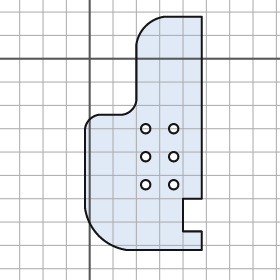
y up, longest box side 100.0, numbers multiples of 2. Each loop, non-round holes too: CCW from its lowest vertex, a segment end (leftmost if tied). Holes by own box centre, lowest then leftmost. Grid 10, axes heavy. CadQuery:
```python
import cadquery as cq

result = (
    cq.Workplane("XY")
    .moveTo(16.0, -82.0)
    .lineTo(48.0, -82.0)
    .lineTo(48.0, -74.0)
    .lineTo(40.0, -74.0)
    .lineTo(40.0, -60.0)
    .lineTo(48.0, -60.0)
    .lineTo(48.0, 18.0)
    .lineTo(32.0, 18.0)
    .threePointArc((24.0, 14.0), (20.0, 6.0))
    .lineTo(20.0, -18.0)
    .threePointArc((18.0, -22.0), (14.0, -24.0))
    .lineTo(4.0, -24.0)
    .threePointArc((0.0, -26.0), (-2.0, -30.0))
    .lineTo(-2.0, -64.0)
    .threePointArc((4.0, -76.0), (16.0, -82.0))
    .close()
    .moveTo(24.0, -54.0)
    .circle(2.0)
    .moveTo(36.0, -54.0)
    .circle(2.0)
    .moveTo(24.0, -42.0)
    .circle(2.0)
    .moveTo(36.0, -42.0)
    .circle(2.0)
    .moveTo(24.0, -30.0)
    .circle(2.0)
    .moveTo(36.0, -30.0)
    .circle(2.0)
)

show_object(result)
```